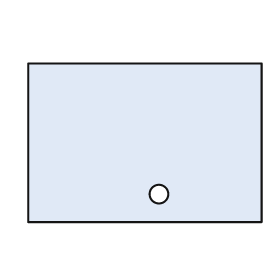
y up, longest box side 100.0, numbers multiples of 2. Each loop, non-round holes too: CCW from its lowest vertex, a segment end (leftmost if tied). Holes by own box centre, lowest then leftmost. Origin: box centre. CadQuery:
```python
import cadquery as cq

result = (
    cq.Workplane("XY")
    .moveTo(-50.0, -34.0)
    .lineTo(50.0, -34.0)
    .lineTo(50.0, 34.0)
    .lineTo(-50.0, 34.0)
    .close()
    .moveTo(6.0, -22.0)
    .circle(4.0)
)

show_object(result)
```